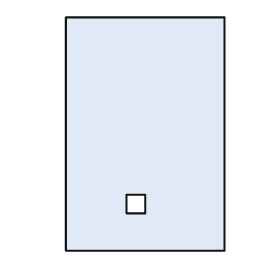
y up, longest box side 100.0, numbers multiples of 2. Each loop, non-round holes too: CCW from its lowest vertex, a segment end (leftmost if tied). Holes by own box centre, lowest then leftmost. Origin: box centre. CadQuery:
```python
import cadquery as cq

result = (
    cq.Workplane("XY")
    .moveTo(-34.0, -50.0)
    .lineTo(34.0, -50.0)
    .lineTo(34.0, 50.0)
    .lineTo(-34.0, 50.0)
    .close()
    .moveTo(-8.0, -34.0)
    .lineTo(0.0, -34.0)
    .lineTo(0.0, -26.0)
    .lineTo(-8.0, -26.0)
    .close()
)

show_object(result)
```